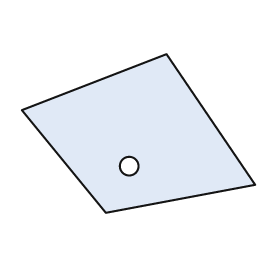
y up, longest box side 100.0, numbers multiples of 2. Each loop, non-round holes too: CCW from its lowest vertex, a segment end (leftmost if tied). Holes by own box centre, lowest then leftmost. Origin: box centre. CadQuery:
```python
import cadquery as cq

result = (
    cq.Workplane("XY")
    .moveTo(-14.0, -34.0)
    .lineTo(50.0, -22.0)
    .lineTo(12.0, 34.0)
    .lineTo(-50.0, 10.0)
    .close()
    .moveTo(-4.0, -14.0)
    .circle(4.0)
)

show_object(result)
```